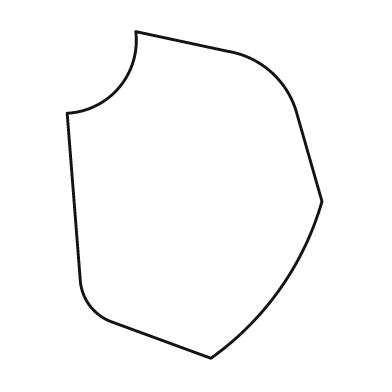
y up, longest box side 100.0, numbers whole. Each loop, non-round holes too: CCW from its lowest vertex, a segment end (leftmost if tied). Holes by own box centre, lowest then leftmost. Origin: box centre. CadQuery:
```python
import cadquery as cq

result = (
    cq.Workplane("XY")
    .moveTo(5.0, -50.0)
    .threePointArc((26.0, -29.0), (39.0, -2.0))
    .lineTo(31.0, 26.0)
    .threePointArc((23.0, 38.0), (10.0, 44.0))
    .lineTo(-18.0, 50.0)
    .threePointArc((-23.0, 33.0), (-39.0, 25.0))
    .lineTo(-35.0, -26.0)
    .threePointArc((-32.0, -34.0), (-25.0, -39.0))
    .close()
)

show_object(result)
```